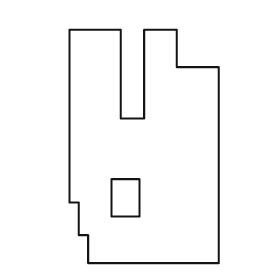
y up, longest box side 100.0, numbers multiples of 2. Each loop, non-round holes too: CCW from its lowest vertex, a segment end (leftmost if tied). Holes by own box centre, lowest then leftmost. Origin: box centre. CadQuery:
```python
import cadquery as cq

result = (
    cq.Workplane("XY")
    .moveTo(-24.0, -50.0)
    .lineTo(32.0, -50.0)
    .lineTo(32.0, 34.0)
    .lineTo(14.0, 34.0)
    .lineTo(14.0, 50.0)
    .lineTo(0.0, 50.0)
    .lineTo(0.0, 12.0)
    .lineTo(-10.0, 12.0)
    .lineTo(-10.0, 50.0)
    .lineTo(-32.0, 50.0)
    .lineTo(-32.0, -24.0)
    .lineTo(-28.0, -24.0)
    .lineTo(-28.0, -38.0)
    .lineTo(-24.0, -38.0)
    .close()
    .moveTo(-14.0, -30.0)
    .lineTo(-2.0, -30.0)
    .lineTo(-2.0, -14.0)
    .lineTo(-14.0, -14.0)
    .close()
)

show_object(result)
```